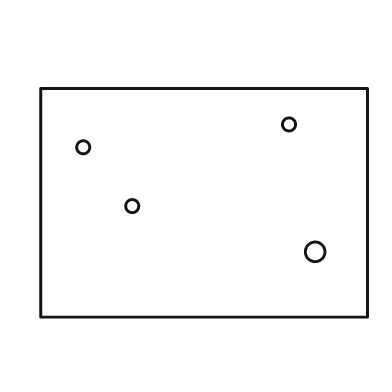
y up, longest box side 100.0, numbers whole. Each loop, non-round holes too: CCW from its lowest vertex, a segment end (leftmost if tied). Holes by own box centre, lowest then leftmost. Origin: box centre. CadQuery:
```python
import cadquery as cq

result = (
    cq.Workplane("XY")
    .moveTo(-50.0, -35.0)
    .lineTo(50.0, -35.0)
    .lineTo(50.0, 35.0)
    .lineTo(-50.0, 35.0)
    .close()
    .moveTo(34.0, -15.0)
    .circle(3.0)
    .moveTo(-22.0, -1.0)
    .circle(2.0)
    .moveTo(-37.0, 17.0)
    .circle(2.0)
    .moveTo(26.0, 24.0)
    .circle(2.0)
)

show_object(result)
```